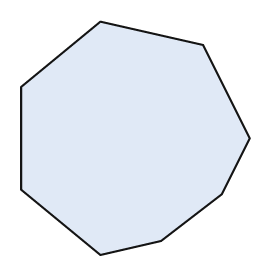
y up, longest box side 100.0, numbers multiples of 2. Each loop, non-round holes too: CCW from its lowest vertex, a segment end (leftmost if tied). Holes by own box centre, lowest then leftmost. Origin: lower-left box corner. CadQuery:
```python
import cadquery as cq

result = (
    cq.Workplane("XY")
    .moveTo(34.0, 0.0)
    .lineTo(60.0, 6.0)
    .lineTo(86.0, 26.0)
    .lineTo(98.0, 50.0)
    .lineTo(78.0, 90.0)
    .lineTo(34.0, 100.0)
    .lineTo(0.0, 72.0)
    .lineTo(0.0, 28.0)
    .close()
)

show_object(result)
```